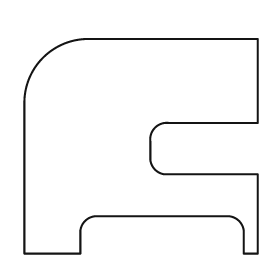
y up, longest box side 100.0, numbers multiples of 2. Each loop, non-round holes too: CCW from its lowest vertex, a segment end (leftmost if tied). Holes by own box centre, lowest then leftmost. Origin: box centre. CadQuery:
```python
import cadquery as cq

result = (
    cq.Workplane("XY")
    .moveTo(-50.0, -46.0)
    .lineTo(-26.0, -46.0)
    .lineTo(-26.0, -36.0)
    .threePointArc((-24.0, -32.0), (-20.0, -30.0))
    .lineTo(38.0, -30.0)
    .threePointArc((42.0, -32.0), (44.0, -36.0))
    .lineTo(44.0, -46.0)
    .lineTo(50.0, -46.0)
    .lineTo(50.0, -12.0)
    .lineTo(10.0, -12.0)
    .threePointArc((6.0, -10.0), (4.0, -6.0))
    .lineTo(4.0, 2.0)
    .threePointArc((6.0, 8.0), (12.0, 10.0))
    .lineTo(50.0, 10.0)
    .lineTo(50.0, 46.0)
    .lineTo(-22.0, 46.0)
    .threePointArc((-42.0, 38.0), (-50.0, 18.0))
    .close()
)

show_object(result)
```